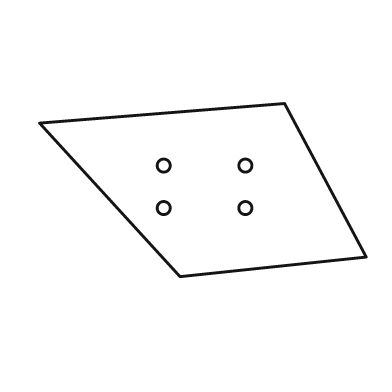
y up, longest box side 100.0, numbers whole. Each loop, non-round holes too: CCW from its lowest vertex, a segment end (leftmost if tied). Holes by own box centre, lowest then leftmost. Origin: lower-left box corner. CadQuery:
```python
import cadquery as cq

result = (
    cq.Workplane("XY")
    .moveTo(43.0, 0.0)
    .lineTo(100.0, 6.0)
    .lineTo(75.0, 53.0)
    .lineTo(0.0, 47.0)
    .close()
    .moveTo(38.0, 21.0)
    .circle(2.0)
    .moveTo(63.0, 21.0)
    .circle(2.0)
    .moveTo(38.0, 34.0)
    .circle(2.0)
    .moveTo(63.0, 34.0)
    .circle(2.0)
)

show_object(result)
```